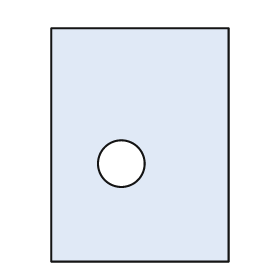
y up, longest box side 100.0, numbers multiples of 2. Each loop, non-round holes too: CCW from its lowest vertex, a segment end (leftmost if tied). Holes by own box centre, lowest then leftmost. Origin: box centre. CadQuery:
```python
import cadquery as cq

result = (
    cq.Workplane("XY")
    .moveTo(-38.0, -50.0)
    .lineTo(38.0, -50.0)
    .lineTo(38.0, 50.0)
    .lineTo(-38.0, 50.0)
    .close()
    .moveTo(-8.0, -8.0)
    .circle(10.0)
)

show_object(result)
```